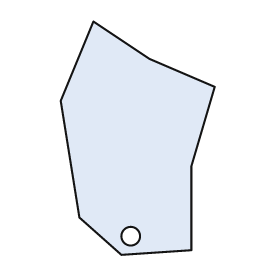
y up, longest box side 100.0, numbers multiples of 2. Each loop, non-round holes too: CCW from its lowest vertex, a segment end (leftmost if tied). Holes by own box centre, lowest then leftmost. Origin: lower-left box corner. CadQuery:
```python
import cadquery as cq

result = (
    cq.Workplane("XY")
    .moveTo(26.0, 0.0)
    .lineTo(56.0, 2.0)
    .lineTo(56.0, 38.0)
    .lineTo(66.0, 72.0)
    .lineTo(38.0, 84.0)
    .lineTo(14.0, 100.0)
    .lineTo(0.0, 66.0)
    .lineTo(8.0, 16.0)
    .close()
    .moveTo(30.0, 8.0)
    .circle(4.0)
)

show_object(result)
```